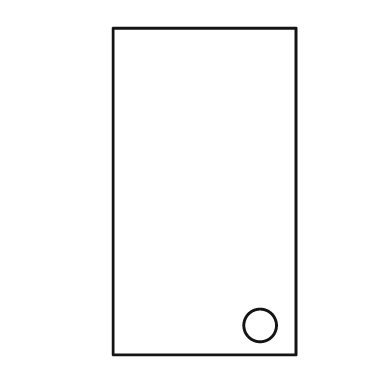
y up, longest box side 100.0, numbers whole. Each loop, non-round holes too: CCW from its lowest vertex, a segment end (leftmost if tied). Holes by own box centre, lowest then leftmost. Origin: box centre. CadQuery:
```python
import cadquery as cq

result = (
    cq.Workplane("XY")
    .moveTo(-28.0, -50.0)
    .lineTo(28.0, -50.0)
    .lineTo(28.0, 50.0)
    .lineTo(-28.0, 50.0)
    .close()
    .moveTo(17.0, -41.0)
    .circle(5.0)
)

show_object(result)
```